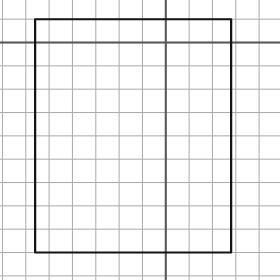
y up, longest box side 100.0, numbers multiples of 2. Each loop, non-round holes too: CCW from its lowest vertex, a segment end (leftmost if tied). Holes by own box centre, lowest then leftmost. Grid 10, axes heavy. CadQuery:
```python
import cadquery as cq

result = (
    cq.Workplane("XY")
    .moveTo(-56.0, -90.0)
    .lineTo(28.0, -90.0)
    .lineTo(28.0, 10.0)
    .lineTo(-56.0, 10.0)
    .close()
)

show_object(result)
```